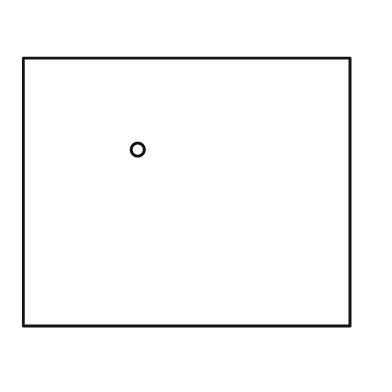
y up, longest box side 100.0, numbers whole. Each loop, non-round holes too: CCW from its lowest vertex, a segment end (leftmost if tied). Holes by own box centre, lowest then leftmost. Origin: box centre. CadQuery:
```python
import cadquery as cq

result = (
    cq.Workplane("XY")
    .moveTo(-50.0, -41.0)
    .lineTo(50.0, -41.0)
    .lineTo(50.0, 41.0)
    .lineTo(-50.0, 41.0)
    .close()
    .moveTo(-15.0, 13.0)
    .circle(2.0)
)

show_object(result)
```